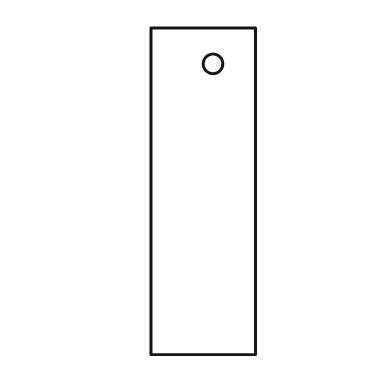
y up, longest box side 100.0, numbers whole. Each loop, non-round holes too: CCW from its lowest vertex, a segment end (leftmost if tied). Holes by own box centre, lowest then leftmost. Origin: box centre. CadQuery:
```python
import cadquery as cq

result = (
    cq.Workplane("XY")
    .moveTo(-16.0, -50.0)
    .lineTo(16.0, -50.0)
    .lineTo(16.0, 50.0)
    .lineTo(-16.0, 50.0)
    .close()
    .moveTo(3.0, 39.0)
    .circle(3.0)
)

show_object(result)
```